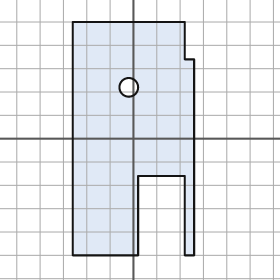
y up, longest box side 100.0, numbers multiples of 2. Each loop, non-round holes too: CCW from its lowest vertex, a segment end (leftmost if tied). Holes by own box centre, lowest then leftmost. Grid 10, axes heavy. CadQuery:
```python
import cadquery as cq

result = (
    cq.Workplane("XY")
    .moveTo(-26.0, -50.0)
    .lineTo(2.0, -50.0)
    .lineTo(2.0, -16.0)
    .lineTo(22.0, -16.0)
    .lineTo(22.0, -50.0)
    .lineTo(26.0, -50.0)
    .lineTo(26.0, 34.0)
    .lineTo(22.0, 34.0)
    .lineTo(22.0, 50.0)
    .lineTo(-26.0, 50.0)
    .close()
    .moveTo(-2.0, 22.0)
    .circle(4.0)
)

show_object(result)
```